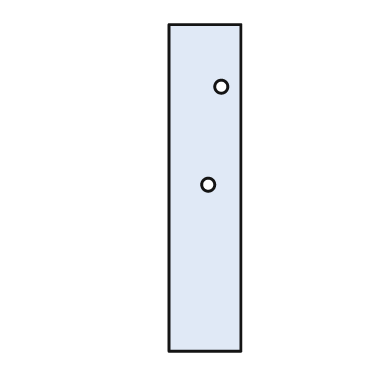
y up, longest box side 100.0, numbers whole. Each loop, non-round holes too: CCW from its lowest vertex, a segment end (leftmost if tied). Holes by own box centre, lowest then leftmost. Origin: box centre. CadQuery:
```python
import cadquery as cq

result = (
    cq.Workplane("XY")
    .moveTo(-11.0, -50.0)
    .lineTo(11.0, -50.0)
    .lineTo(11.0, 50.0)
    .lineTo(-11.0, 50.0)
    .close()
    .moveTo(1.0, 1.0)
    .circle(2.0)
    .moveTo(5.0, 31.0)
    .circle(2.0)
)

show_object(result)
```